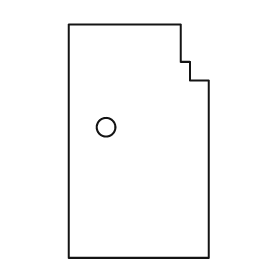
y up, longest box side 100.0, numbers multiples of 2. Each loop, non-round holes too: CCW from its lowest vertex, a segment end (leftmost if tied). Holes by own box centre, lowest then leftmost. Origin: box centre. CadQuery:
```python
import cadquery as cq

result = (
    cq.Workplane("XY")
    .moveTo(-30.0, -50.0)
    .lineTo(30.0, -50.0)
    .lineTo(30.0, 26.0)
    .lineTo(22.0, 26.0)
    .lineTo(22.0, 34.0)
    .lineTo(18.0, 34.0)
    .lineTo(18.0, 50.0)
    .lineTo(-30.0, 50.0)
    .close()
    .moveTo(-14.0, 6.0)
    .circle(4.0)
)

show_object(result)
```